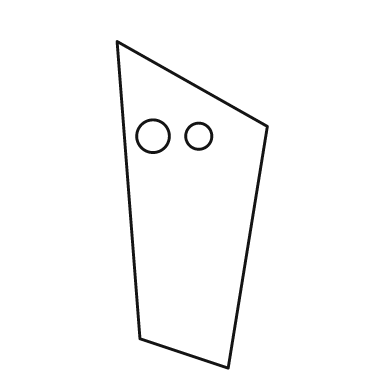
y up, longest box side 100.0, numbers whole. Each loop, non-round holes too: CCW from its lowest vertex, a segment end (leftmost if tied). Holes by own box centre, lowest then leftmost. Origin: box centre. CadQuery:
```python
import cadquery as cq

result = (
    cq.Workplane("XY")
    .moveTo(11.0, -50.0)
    .lineTo(23.0, 24.0)
    .lineTo(-23.0, 50.0)
    .lineTo(-16.0, -41.0)
    .close()
    .moveTo(-12.0, 21.0)
    .circle(5.0)
    .moveTo(2.0, 21.0)
    .circle(4.0)
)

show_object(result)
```